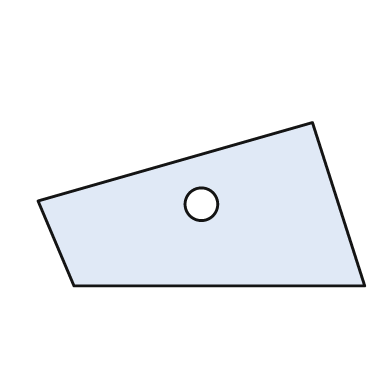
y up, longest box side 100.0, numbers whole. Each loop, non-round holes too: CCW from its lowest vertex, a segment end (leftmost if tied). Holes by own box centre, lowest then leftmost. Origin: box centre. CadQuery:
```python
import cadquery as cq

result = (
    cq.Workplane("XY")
    .moveTo(-39.0, -25.0)
    .lineTo(50.0, -25.0)
    .lineTo(34.0, 25.0)
    .lineTo(-50.0, 1.0)
    .close()
    .moveTo(0.0, 0.0)
    .circle(5.0)
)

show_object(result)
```